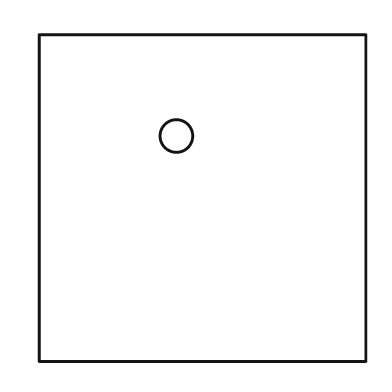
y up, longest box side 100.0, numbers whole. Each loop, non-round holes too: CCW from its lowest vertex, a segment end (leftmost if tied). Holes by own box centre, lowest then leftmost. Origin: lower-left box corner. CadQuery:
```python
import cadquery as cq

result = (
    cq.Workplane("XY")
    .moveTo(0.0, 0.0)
    .lineTo(100.0, 0.0)
    .lineTo(100.0, 100.0)
    .lineTo(0.0, 100.0)
    .close()
    .moveTo(42.0, 69.0)
    .circle(5.0)
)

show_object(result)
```